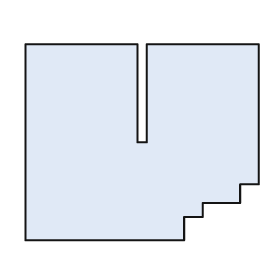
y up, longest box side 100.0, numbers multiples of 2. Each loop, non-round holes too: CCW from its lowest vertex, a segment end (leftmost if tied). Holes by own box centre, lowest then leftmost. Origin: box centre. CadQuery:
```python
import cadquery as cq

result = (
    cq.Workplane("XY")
    .moveTo(-50.0, -42.0)
    .lineTo(18.0, -42.0)
    .lineTo(18.0, -32.0)
    .lineTo(26.0, -32.0)
    .lineTo(26.0, -26.0)
    .lineTo(42.0, -26.0)
    .lineTo(42.0, -18.0)
    .lineTo(50.0, -18.0)
    .lineTo(50.0, 42.0)
    .lineTo(2.0, 42.0)
    .lineTo(2.0, 0.0)
    .lineTo(-2.0, 0.0)
    .lineTo(-2.0, 42.0)
    .lineTo(-50.0, 42.0)
    .close()
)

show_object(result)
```